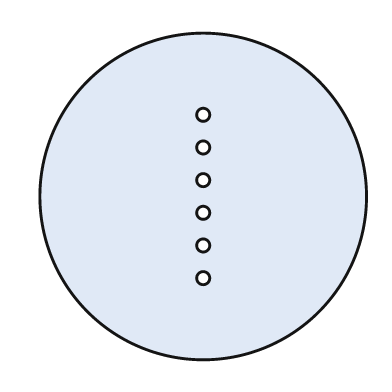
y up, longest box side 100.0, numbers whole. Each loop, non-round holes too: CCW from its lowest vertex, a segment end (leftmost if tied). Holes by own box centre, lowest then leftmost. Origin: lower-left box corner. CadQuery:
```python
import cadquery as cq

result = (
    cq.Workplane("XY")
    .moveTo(50.0, 50.0)
    .circle(50.0)
    .moveTo(50.0, 25.0)
    .circle(2.0)
    .moveTo(50.0, 35.0)
    .circle(2.0)
    .moveTo(50.0, 45.0)
    .circle(2.0)
    .moveTo(50.0, 55.0)
    .circle(2.0)
    .moveTo(50.0, 65.0)
    .circle(2.0)
    .moveTo(50.0, 75.0)
    .circle(2.0)
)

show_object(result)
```